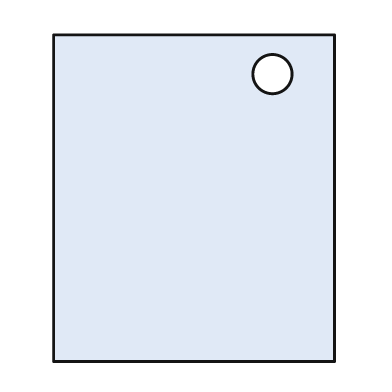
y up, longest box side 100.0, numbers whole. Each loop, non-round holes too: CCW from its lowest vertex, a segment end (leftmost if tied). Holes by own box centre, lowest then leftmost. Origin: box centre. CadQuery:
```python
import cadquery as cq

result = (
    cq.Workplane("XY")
    .moveTo(-43.0, -50.0)
    .lineTo(43.0, -50.0)
    .lineTo(43.0, 50.0)
    .lineTo(-43.0, 50.0)
    .close()
    .moveTo(24.0, 38.0)
    .circle(6.0)
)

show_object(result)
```